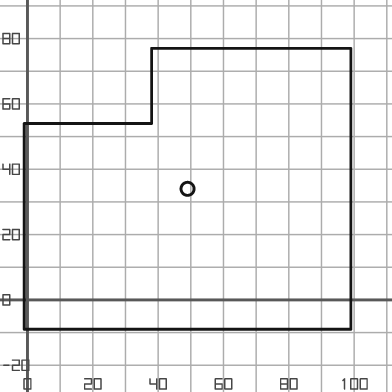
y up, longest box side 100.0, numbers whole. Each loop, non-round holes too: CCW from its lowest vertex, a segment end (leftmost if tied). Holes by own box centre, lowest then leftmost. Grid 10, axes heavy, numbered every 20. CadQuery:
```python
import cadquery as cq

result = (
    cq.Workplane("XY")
    .moveTo(-1.0, -9.0)
    .lineTo(99.0, -9.0)
    .lineTo(99.0, 77.0)
    .lineTo(38.0, 77.0)
    .lineTo(38.0, 54.0)
    .lineTo(-1.0, 54.0)
    .close()
    .moveTo(49.0, 34.0)
    .circle(2.0)
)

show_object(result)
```